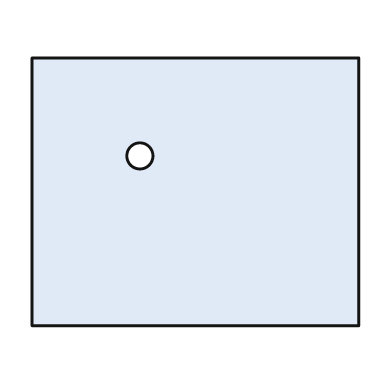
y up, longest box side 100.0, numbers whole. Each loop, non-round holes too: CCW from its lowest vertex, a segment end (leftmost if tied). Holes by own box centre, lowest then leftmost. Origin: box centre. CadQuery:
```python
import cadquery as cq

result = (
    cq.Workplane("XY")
    .moveTo(-50.0, -41.0)
    .lineTo(50.0, -41.0)
    .lineTo(50.0, 41.0)
    .lineTo(-50.0, 41.0)
    .close()
    .moveTo(-17.0, 11.0)
    .circle(4.0)
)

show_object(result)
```